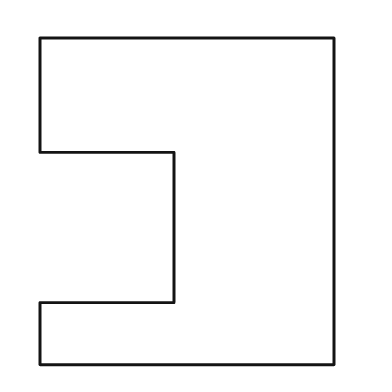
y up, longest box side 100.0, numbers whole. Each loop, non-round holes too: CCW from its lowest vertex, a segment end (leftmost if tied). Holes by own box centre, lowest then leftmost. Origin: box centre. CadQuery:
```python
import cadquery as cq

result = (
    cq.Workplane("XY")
    .moveTo(-45.0, -50.0)
    .lineTo(45.0, -50.0)
    .lineTo(45.0, 50.0)
    .lineTo(-45.0, 50.0)
    .lineTo(-45.0, 15.0)
    .lineTo(-4.0, 15.0)
    .lineTo(-4.0, -31.0)
    .lineTo(-45.0, -31.0)
    .close()
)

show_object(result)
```